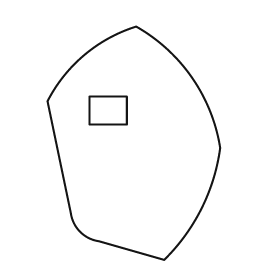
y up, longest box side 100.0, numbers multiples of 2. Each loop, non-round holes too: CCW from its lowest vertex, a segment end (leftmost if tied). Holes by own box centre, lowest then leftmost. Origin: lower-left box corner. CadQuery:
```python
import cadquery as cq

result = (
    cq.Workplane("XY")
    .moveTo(50.0, 0.0)
    .threePointArc((66.0, 22.0), (74.0, 48.0))
    .threePointArc((62.0, 78.0), (38.0, 100.0))
    .threePointArc((16.0, 88.0), (0.0, 68.0))
    .lineTo(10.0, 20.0)
    .threePointArc((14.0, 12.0), (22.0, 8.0))
    .close()
    .moveTo(18.0, 58.0)
    .lineTo(34.0, 58.0)
    .lineTo(34.0, 70.0)
    .lineTo(18.0, 70.0)
    .close()
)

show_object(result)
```